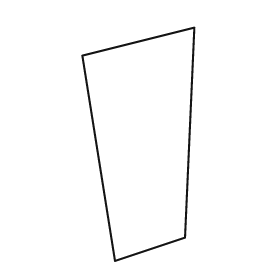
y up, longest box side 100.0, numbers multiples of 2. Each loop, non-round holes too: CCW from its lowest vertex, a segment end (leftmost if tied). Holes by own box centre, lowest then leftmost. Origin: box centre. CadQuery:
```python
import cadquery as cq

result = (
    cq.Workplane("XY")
    .moveTo(-10.0, -50.0)
    .lineTo(20.0, -40.0)
    .lineTo(24.0, 50.0)
    .lineTo(-24.0, 38.0)
    .close()
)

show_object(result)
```